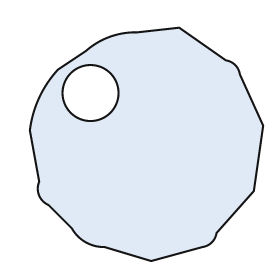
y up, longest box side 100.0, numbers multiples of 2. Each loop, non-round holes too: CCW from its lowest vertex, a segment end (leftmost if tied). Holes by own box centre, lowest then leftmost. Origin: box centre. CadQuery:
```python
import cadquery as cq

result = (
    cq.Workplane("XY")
    .moveTo(2.0, -50.0)
    .lineTo(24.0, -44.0)
    .threePointArc((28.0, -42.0), (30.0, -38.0))
    .lineTo(46.0, -20.0)
    .lineTo(50.0, 8.0)
    .lineTo(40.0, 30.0)
    .threePointArc((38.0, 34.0), (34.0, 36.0))
    .lineTo(14.0, 50.0)
    .lineTo(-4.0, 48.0)
    .threePointArc((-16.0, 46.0), (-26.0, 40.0))
    .lineTo(-38.0, 32.0)
    .threePointArc((-46.0, 20.0), (-50.0, 6.0))
    .lineTo(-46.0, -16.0)
    .threePointArc((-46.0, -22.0), (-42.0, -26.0))
    .lineTo(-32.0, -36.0)
    .threePointArc((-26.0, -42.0), (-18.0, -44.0))
    .close()
    .moveTo(-24.0, 22.0)
    .circle(12.0)
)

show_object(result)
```